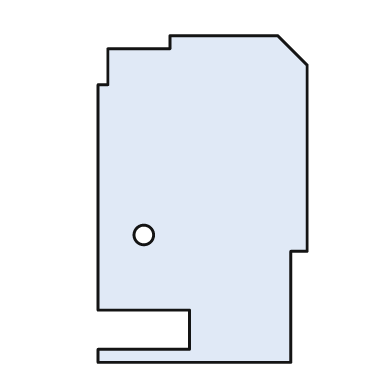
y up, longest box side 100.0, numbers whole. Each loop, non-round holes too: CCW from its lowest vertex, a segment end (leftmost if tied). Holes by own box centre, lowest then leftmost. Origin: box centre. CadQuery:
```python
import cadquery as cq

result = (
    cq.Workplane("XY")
    .moveTo(-32.0, -50.0)
    .lineTo(27.0, -50.0)
    .lineTo(27.0, -16.0)
    .lineTo(32.0, -16.0)
    .lineTo(32.0, 41.0)
    .lineTo(23.0, 50.0)
    .lineTo(-10.0, 50.0)
    .lineTo(-10.0, 46.0)
    .lineTo(-29.0, 46.0)
    .lineTo(-29.0, 35.0)
    .lineTo(-32.0, 35.0)
    .lineTo(-32.0, -34.0)
    .lineTo(-4.0, -34.0)
    .lineTo(-4.0, -46.0)
    .lineTo(-32.0, -46.0)
    .close()
    .moveTo(-18.0, -11.0)
    .circle(3.0)
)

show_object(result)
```